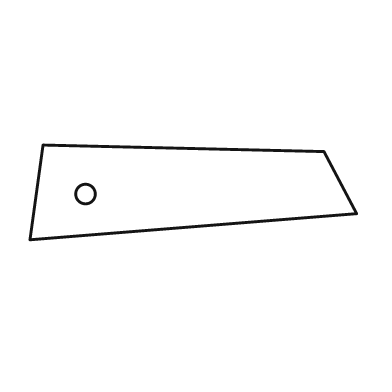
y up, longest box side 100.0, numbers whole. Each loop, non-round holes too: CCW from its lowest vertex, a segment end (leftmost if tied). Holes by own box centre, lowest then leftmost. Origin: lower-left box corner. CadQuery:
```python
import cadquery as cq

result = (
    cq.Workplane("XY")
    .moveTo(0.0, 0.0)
    .lineTo(100.0, 8.0)
    .lineTo(90.0, 27.0)
    .lineTo(4.0, 29.0)
    .close()
    .moveTo(17.0, 14.0)
    .circle(3.0)
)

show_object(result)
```